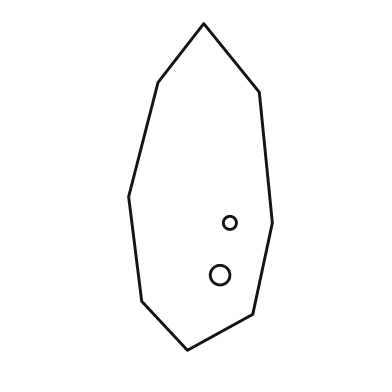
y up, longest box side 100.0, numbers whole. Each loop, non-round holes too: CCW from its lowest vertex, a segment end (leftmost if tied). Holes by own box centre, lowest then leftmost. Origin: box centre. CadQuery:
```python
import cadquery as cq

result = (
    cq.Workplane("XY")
    .moveTo(-4.0, -50.0)
    .lineTo(16.0, -39.0)
    .lineTo(22.0, -11.0)
    .lineTo(18.0, 29.0)
    .lineTo(1.0, 50.0)
    .lineTo(-13.0, 32.0)
    .lineTo(-22.0, -3.0)
    .lineTo(-18.0, -35.0)
    .close()
    .moveTo(6.0, -27.0)
    .circle(3.0)
    .moveTo(9.0, -11.0)
    .circle(2.0)
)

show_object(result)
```